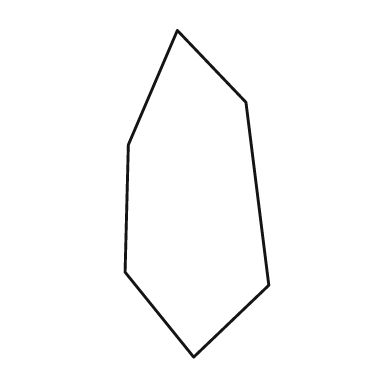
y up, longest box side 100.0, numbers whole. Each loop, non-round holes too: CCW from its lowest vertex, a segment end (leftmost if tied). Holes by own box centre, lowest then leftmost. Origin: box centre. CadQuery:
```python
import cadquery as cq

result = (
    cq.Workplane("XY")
    .moveTo(-1.0, -50.0)
    .lineTo(22.0, -28.0)
    .lineTo(15.0, 28.0)
    .lineTo(-6.0, 50.0)
    .lineTo(-21.0, 15.0)
    .lineTo(-22.0, -24.0)
    .close()
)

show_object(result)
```